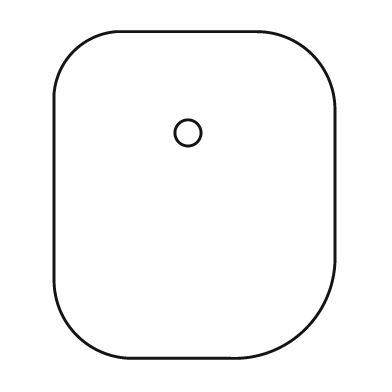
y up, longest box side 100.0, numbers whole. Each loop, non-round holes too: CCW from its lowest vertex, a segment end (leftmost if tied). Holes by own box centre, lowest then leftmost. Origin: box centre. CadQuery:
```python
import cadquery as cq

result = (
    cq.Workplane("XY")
    .moveTo(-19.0, -50.0)
    .lineTo(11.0, -50.0)
    .threePointArc((34.0, -41.0), (43.0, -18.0))
    .lineTo(43.0, 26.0)
    .threePointArc((36.0, 43.0), (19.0, 50.0))
    .lineTo(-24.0, 50.0)
    .threePointArc((-37.0, 44.0), (-43.0, 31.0))
    .lineTo(-43.0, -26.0)
    .threePointArc((-36.0, -43.0), (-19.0, -50.0))
    .close()
    .moveTo(-2.0, 19.0)
    .circle(4.0)
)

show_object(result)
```